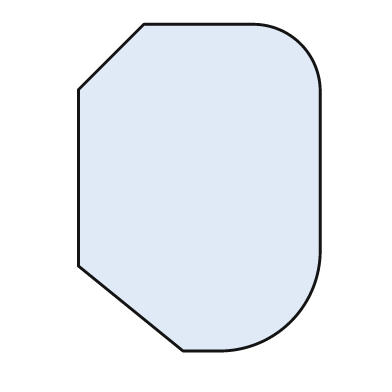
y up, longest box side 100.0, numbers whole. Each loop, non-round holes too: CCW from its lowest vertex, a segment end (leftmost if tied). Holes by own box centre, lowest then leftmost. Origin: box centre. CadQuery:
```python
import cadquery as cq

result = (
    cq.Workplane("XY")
    .moveTo(-5.0, -50.0)
    .lineTo(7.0, -50.0)
    .threePointArc((28.0, -41.0), (37.0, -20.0))
    .lineTo(37.0, 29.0)
    .threePointArc((31.0, 44.0), (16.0, 50.0))
    .lineTo(-17.0, 50.0)
    .lineTo(-37.0, 30.0)
    .lineTo(-37.0, -24.0)
    .close()
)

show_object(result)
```